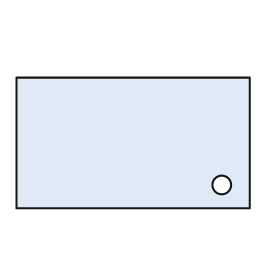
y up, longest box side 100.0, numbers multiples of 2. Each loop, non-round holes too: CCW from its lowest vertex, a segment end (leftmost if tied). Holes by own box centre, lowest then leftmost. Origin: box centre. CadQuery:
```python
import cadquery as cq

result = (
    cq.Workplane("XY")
    .moveTo(-50.0, -28.0)
    .lineTo(50.0, -28.0)
    .lineTo(50.0, 28.0)
    .lineTo(-50.0, 28.0)
    .close()
    .moveTo(38.0, -18.0)
    .circle(4.0)
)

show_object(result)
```